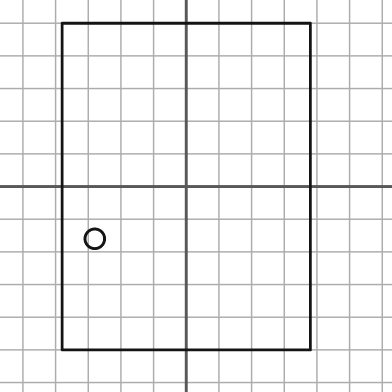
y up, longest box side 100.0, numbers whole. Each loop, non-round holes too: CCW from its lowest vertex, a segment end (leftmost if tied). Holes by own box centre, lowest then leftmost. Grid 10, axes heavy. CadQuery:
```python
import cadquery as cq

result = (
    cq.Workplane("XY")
    .moveTo(-38.0, -50.0)
    .lineTo(38.0, -50.0)
    .lineTo(38.0, 50.0)
    .lineTo(-38.0, 50.0)
    .close()
    .moveTo(-28.0, -16.0)
    .circle(3.0)
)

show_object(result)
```